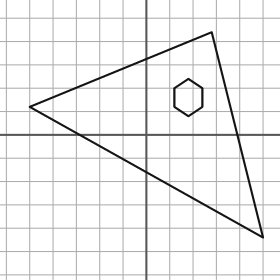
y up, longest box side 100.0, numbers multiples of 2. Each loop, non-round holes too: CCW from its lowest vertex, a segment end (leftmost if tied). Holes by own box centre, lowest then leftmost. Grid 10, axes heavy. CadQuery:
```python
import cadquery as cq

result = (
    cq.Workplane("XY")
    .moveTo(50.0, -44.0)
    .lineTo(28.0, 44.0)
    .lineTo(-50.0, 12.0)
    .close()
    .moveTo(18.0, 8.0)
    .lineTo(24.0, 12.0)
    .lineTo(24.0, 20.0)
    .lineTo(18.0, 24.0)
    .lineTo(12.0, 20.0)
    .lineTo(12.0, 12.0)
    .close()
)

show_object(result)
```